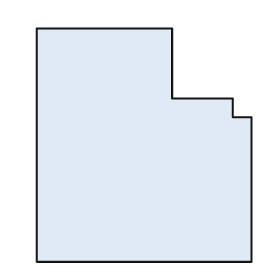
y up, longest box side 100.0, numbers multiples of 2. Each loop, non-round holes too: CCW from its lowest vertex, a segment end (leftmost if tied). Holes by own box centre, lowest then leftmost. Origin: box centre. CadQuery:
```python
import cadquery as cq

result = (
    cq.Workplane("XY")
    .moveTo(-46.0, -50.0)
    .lineTo(46.0, -50.0)
    .lineTo(46.0, 12.0)
    .lineTo(38.0, 12.0)
    .lineTo(38.0, 20.0)
    .lineTo(12.0, 20.0)
    .lineTo(12.0, 50.0)
    .lineTo(-46.0, 50.0)
    .close()
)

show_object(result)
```